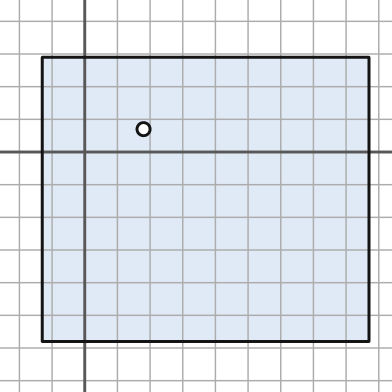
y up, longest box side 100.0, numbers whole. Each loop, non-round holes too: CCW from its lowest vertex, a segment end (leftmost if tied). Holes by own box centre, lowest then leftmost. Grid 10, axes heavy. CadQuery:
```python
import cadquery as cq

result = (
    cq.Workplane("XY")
    .moveTo(-13.0, -58.0)
    .lineTo(87.0, -58.0)
    .lineTo(87.0, 29.0)
    .lineTo(-13.0, 29.0)
    .close()
    .moveTo(18.0, 7.0)
    .circle(2.0)
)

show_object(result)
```